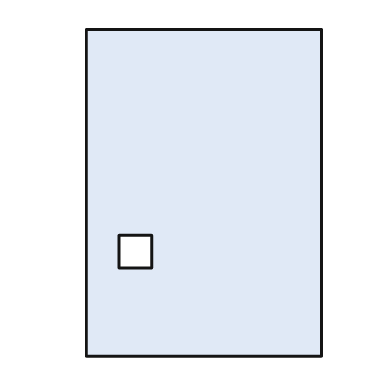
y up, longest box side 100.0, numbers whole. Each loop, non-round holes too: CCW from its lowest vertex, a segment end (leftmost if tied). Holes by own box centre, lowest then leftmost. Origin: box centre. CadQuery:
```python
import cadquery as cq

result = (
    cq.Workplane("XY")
    .moveTo(-36.0, -50.0)
    .lineTo(36.0, -50.0)
    .lineTo(36.0, 50.0)
    .lineTo(-36.0, 50.0)
    .close()
    .moveTo(-26.0, -23.0)
    .lineTo(-16.0, -23.0)
    .lineTo(-16.0, -13.0)
    .lineTo(-26.0, -13.0)
    .close()
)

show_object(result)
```